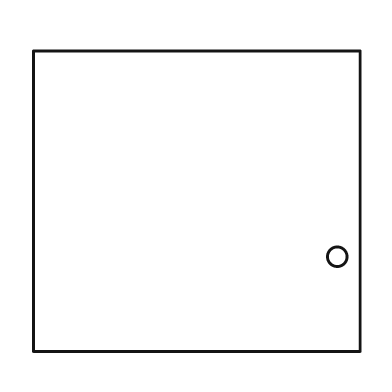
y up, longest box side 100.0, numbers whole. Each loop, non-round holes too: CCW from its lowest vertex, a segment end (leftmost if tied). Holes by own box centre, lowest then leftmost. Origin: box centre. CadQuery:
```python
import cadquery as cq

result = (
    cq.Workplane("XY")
    .moveTo(-50.0, -46.0)
    .lineTo(50.0, -46.0)
    .lineTo(50.0, 46.0)
    .lineTo(-50.0, 46.0)
    .close()
    .moveTo(43.0, -17.0)
    .circle(3.0)
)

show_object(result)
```